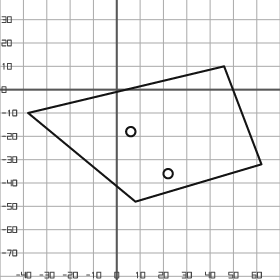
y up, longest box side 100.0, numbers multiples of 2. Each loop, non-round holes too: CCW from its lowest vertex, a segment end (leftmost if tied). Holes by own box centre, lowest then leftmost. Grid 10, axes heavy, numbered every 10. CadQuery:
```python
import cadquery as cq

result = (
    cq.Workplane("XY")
    .moveTo(8.0, -48.0)
    .lineTo(62.0, -32.0)
    .lineTo(46.0, 10.0)
    .lineTo(-38.0, -10.0)
    .close()
    .moveTo(22.0, -36.0)
    .circle(2.0)
    .moveTo(6.0, -18.0)
    .circle(2.0)
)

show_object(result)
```